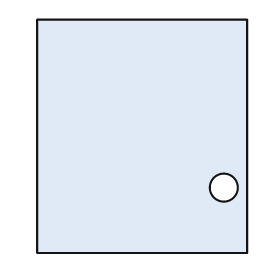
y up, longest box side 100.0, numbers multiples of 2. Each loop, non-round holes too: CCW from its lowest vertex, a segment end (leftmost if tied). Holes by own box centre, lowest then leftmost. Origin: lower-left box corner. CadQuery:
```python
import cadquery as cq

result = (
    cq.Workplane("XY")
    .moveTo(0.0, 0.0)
    .lineTo(90.0, 0.0)
    .lineTo(90.0, 100.0)
    .lineTo(0.0, 100.0)
    .close()
    .moveTo(80.0, 28.0)
    .circle(6.0)
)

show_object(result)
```